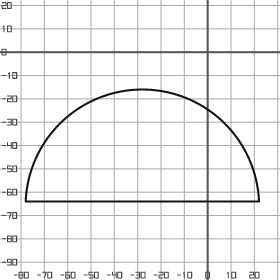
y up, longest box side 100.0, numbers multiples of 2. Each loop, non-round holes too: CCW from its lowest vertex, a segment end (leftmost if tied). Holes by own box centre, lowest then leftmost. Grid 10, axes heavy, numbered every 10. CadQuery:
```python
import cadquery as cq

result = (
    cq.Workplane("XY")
    .moveTo(-78.0, -64.0)
    .lineTo(22.0, -64.0)
    .threePointArc((-28.0, -16.0), (-78.0, -64.0))
    .close()
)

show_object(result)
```